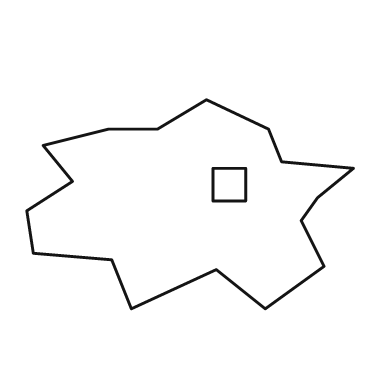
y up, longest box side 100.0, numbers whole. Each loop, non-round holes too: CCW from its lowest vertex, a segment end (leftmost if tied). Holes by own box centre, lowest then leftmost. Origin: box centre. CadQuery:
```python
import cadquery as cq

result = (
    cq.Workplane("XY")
    .moveTo(-18.0, -32.0)
    .lineTo(8.0, -20.0)
    .lineTo(23.0, -32.0)
    .lineTo(41.0, -19.0)
    .lineTo(34.0, -5.0)
    .lineTo(39.0, 2.0)
    .lineTo(50.0, 11.0)
    .lineTo(28.0, 13.0)
    .lineTo(24.0, 23.0)
    .lineTo(5.0, 32.0)
    .lineTo(-10.0, 23.0)
    .lineTo(-25.0, 23.0)
    .lineTo(-45.0, 18.0)
    .lineTo(-36.0, 7.0)
    .lineTo(-50.0, -2.0)
    .lineTo(-48.0, -15.0)
    .lineTo(-24.0, -17.0)
    .close()
    .moveTo(7.0, 1.0)
    .lineTo(17.0, 1.0)
    .lineTo(17.0, 11.0)
    .lineTo(7.0, 11.0)
    .close()
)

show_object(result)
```